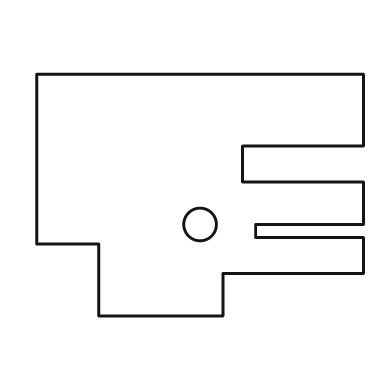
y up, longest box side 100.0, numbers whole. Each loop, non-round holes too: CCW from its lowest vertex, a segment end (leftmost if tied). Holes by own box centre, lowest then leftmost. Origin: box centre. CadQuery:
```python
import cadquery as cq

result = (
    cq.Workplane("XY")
    .moveTo(-31.0, -37.0)
    .lineTo(7.0, -37.0)
    .lineTo(7.0, -24.0)
    .lineTo(50.0, -24.0)
    .lineTo(50.0, -13.0)
    .lineTo(17.0, -13.0)
    .lineTo(17.0, -9.0)
    .lineTo(50.0, -9.0)
    .lineTo(50.0, 4.0)
    .lineTo(13.0, 4.0)
    .lineTo(13.0, 15.0)
    .lineTo(50.0, 15.0)
    .lineTo(50.0, 37.0)
    .lineTo(-50.0, 37.0)
    .lineTo(-50.0, -15.0)
    .lineTo(-31.0, -15.0)
    .close()
    .moveTo(0.0, -9.0)
    .circle(5.0)
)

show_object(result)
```